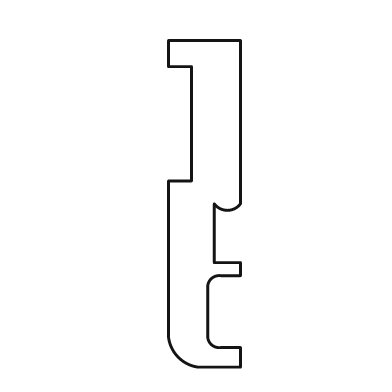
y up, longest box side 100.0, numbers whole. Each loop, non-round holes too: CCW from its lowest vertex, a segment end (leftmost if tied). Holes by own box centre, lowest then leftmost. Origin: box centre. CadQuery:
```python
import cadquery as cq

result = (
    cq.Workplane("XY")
    .moveTo(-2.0, -50.0)
    .lineTo(11.0, -50.0)
    .lineTo(11.0, -44.0)
    .lineTo(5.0, -44.0)
    .threePointArc((2.0, -43.0), (1.0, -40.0))
    .lineTo(1.0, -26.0)
    .threePointArc((2.0, -23.0), (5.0, -22.0))
    .lineTo(11.0, -22.0)
    .lineTo(11.0, -18.0)
    .lineTo(3.0, -18.0)
    .lineTo(3.0, 0.0)
    .threePointArc((7.0, -2.0), (11.0, 0.0))
    .lineTo(11.0, 50.0)
    .lineTo(-11.0, 50.0)
    .lineTo(-11.0, 42.0)
    .lineTo(-4.0, 42.0)
    .lineTo(-4.0, 7.0)
    .lineTo(-11.0, 7.0)
    .lineTo(-11.0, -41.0)
    .threePointArc((-8.0, -47.0), (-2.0, -50.0))
    .close()
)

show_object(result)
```